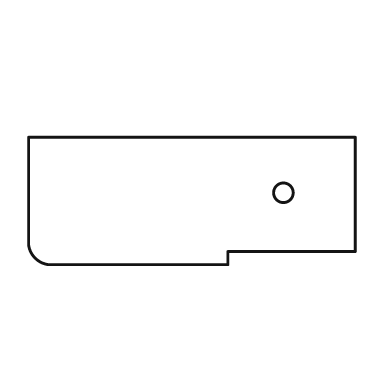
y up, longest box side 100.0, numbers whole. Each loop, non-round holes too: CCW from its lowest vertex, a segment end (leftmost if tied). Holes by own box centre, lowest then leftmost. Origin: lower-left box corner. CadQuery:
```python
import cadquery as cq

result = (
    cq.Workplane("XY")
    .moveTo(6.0, 0.0)
    .lineTo(61.0, 0.0)
    .lineTo(61.0, 4.0)
    .lineTo(100.0, 4.0)
    .lineTo(100.0, 39.0)
    .lineTo(0.0, 39.0)
    .lineTo(0.0, 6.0)
    .threePointArc((2.0, 2.0), (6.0, 0.0))
    .close()
    .moveTo(78.0, 22.0)
    .circle(3.0)
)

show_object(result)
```